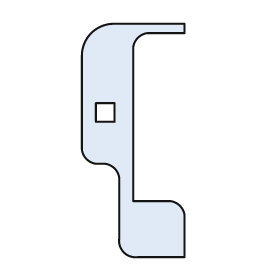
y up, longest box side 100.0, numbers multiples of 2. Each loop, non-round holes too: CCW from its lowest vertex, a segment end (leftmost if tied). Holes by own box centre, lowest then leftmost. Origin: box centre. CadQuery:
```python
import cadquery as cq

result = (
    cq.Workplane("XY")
    .moveTo(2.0, -50.0)
    .lineTo(22.0, -50.0)
    .lineTo(22.0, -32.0)
    .threePointArc((20.0, -28.0), (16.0, -26.0))
    .lineTo(0.0, -26.0)
    .lineTo(0.0, 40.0)
    .threePointArc((2.0, 44.0), (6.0, 46.0))
    .lineTo(22.0, 46.0)
    .lineTo(22.0, 50.0)
    .lineTo(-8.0, 50.0)
    .threePointArc((-18.0, 46.0), (-22.0, 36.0))
    .lineTo(-22.0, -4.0)
    .threePointArc((-20.0, -8.0), (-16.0, -10.0))
    .lineTo(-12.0, -10.0)
    .threePointArc((-8.0, -12.0), (-6.0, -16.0))
    .lineTo(-6.0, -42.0)
    .threePointArc((-4.0, -48.0), (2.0, -50.0))
    .close()
    .moveTo(-16.0, 8.0)
    .lineTo(-8.0, 8.0)
    .lineTo(-8.0, 16.0)
    .lineTo(-16.0, 16.0)
    .close()
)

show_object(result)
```